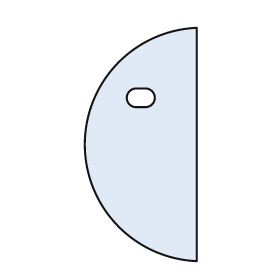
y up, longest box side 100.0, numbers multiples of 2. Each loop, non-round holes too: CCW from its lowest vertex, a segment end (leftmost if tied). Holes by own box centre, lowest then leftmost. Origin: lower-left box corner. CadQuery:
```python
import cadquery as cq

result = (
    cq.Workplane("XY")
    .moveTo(48.0, 0.0)
    .lineTo(48.0, 100.0)
    .threePointArc((0.0, 50.0), (48.0, 0.0))
    .close()
    .moveTo(22.0, 66.0)
    .lineTo(26.0, 66.0)
    .threePointArc((30.0, 70.0), (26.0, 74.0))
    .lineTo(22.0, 74.0)
    .threePointArc((18.0, 70.0), (22.0, 66.0))
    .close()
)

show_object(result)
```